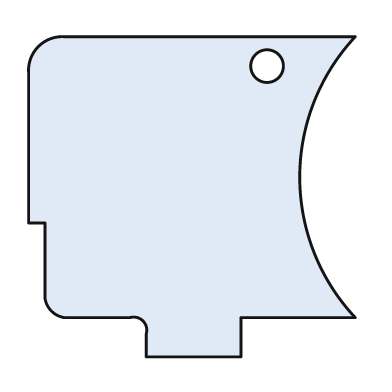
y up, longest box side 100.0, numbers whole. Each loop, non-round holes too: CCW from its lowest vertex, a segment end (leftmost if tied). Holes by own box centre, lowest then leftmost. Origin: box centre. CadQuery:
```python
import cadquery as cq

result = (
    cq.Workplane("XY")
    .moveTo(-14.0, -49.0)
    .lineTo(15.0, -49.0)
    .lineTo(15.0, -37.0)
    .lineTo(50.0, -37.0)
    .threePointArc((33.0, 6.0), (50.0, 49.0))
    .lineTo(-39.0, 49.0)
    .threePointArc((-47.0, 46.0), (-50.0, 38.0))
    .lineTo(-50.0, -8.0)
    .lineTo(-45.0, -8.0)
    .lineTo(-45.0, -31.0)
    .threePointArc((-43.0, -35.0), (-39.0, -37.0))
    .lineTo(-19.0, -37.0)
    .threePointArc((-15.0, -38.0), (-14.0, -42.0))
    .close()
    .moveTo(23.0, 40.0)
    .circle(5.0)
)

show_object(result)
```